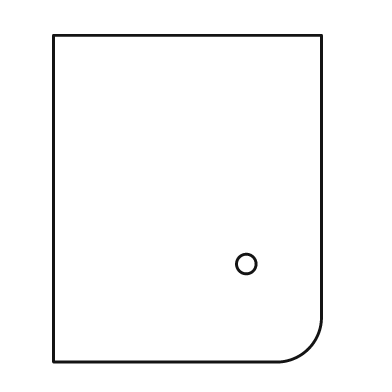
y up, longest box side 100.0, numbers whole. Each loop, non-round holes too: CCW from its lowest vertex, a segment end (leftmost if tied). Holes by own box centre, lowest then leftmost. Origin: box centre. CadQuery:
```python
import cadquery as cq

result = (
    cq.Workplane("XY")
    .moveTo(-41.0, -50.0)
    .lineTo(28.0, -50.0)
    .threePointArc((37.0, -46.0), (41.0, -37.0))
    .lineTo(41.0, 50.0)
    .lineTo(-41.0, 50.0)
    .close()
    .moveTo(18.0, -20.0)
    .circle(3.0)
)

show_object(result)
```